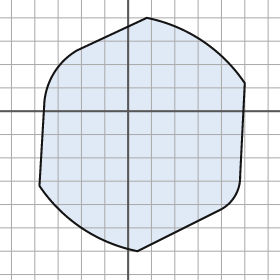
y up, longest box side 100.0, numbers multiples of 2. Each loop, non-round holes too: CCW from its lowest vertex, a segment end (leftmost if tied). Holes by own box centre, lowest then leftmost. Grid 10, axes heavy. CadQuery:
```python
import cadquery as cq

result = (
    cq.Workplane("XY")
    .moveTo(4.0, -60.0)
    .lineTo(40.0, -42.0)
    .threePointArc((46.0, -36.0), (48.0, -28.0))
    .lineTo(50.0, 12.0)
    .threePointArc((32.0, 30.0), (8.0, 40.0))
    .lineTo(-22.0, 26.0)
    .threePointArc((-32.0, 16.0), (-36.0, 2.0))
    .lineTo(-38.0, -32.0)
    .threePointArc((-20.0, -50.0), (4.0, -60.0))
    .close()
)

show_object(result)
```